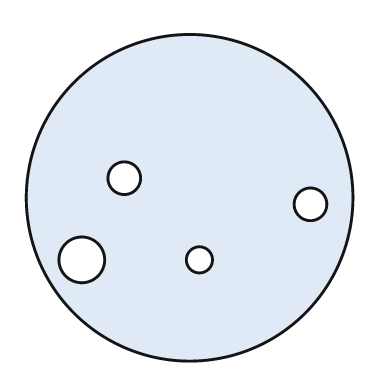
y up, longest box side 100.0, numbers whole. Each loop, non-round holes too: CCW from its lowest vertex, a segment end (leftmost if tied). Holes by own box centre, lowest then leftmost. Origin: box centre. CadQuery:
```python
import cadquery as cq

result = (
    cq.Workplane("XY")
    .moveTo(0.0, 0.0)
    .circle(50.0)
    .moveTo(-33.0, -19.0)
    .circle(7.0)
    .moveTo(3.0, -19.0)
    .circle(4.0)
    .moveTo(37.0, -2.0)
    .circle(5.0)
    .moveTo(-20.0, 6.0)
    .circle(5.0)
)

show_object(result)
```